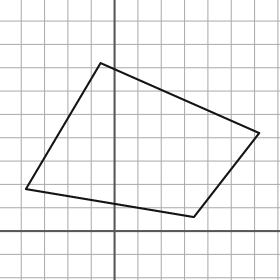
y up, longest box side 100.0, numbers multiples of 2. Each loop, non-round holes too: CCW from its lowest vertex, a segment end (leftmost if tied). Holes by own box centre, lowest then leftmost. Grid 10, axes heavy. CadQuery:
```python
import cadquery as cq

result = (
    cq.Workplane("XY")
    .moveTo(34.0, 6.0)
    .lineTo(62.0, 42.0)
    .lineTo(-6.0, 72.0)
    .lineTo(-38.0, 18.0)
    .close()
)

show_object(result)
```